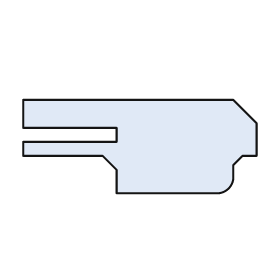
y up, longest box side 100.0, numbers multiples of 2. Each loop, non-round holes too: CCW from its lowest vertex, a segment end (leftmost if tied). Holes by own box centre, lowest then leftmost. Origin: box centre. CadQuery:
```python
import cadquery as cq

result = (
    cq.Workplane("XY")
    .moveTo(-10.0, -20.0)
    .lineTo(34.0, -20.0)
    .threePointArc((38.0, -18.0), (40.0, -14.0))
    .lineTo(40.0, -8.0)
    .lineTo(44.0, -4.0)
    .lineTo(50.0, -4.0)
    .lineTo(50.0, 10.0)
    .lineTo(40.0, 20.0)
    .lineTo(-50.0, 20.0)
    .lineTo(-50.0, 8.0)
    .lineTo(-10.0, 8.0)
    .lineTo(-10.0, 2.0)
    .lineTo(-50.0, 2.0)
    .lineTo(-50.0, -4.0)
    .lineTo(-16.0, -4.0)
    .lineTo(-10.0, -10.0)
    .close()
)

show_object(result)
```